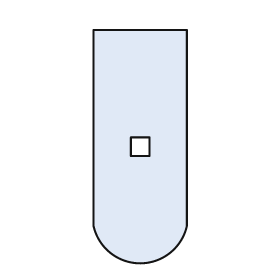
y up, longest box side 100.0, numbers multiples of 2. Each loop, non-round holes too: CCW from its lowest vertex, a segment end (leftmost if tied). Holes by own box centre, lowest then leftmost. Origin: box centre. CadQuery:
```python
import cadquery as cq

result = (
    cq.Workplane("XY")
    .moveTo(-20.0, -34.0)
    .threePointArc((0.0, -50.0), (20.0, -34.0))
    .lineTo(20.0, 50.0)
    .lineTo(-20.0, 50.0)
    .close()
    .moveTo(-4.0, -4.0)
    .lineTo(4.0, -4.0)
    .lineTo(4.0, 4.0)
    .lineTo(-4.0, 4.0)
    .close()
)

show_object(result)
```